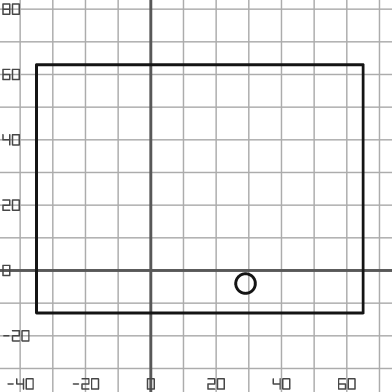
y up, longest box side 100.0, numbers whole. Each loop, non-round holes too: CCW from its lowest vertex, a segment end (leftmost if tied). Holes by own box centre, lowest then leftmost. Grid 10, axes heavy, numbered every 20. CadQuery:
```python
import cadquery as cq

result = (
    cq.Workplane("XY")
    .moveTo(-35.0, -13.0)
    .lineTo(65.0, -13.0)
    .lineTo(65.0, 63.0)
    .lineTo(-35.0, 63.0)
    .close()
    .moveTo(29.0, -4.0)
    .circle(3.0)
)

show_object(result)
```